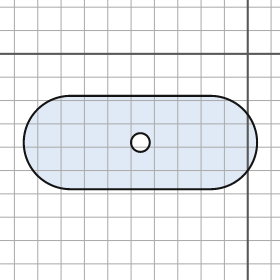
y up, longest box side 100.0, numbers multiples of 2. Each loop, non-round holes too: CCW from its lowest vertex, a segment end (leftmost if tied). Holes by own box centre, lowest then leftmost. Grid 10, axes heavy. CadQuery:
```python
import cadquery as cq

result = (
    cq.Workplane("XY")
    .moveTo(-76.0, -58.0)
    .lineTo(-16.0, -58.0)
    .threePointArc((4.0, -38.0), (-16.0, -18.0))
    .lineTo(-76.0, -18.0)
    .threePointArc((-96.0, -38.0), (-76.0, -58.0))
    .close()
    .moveTo(-46.0, -38.0)
    .circle(4.0)
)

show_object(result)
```